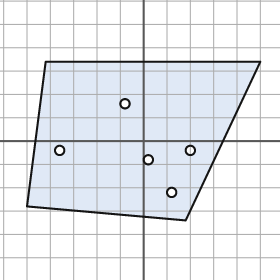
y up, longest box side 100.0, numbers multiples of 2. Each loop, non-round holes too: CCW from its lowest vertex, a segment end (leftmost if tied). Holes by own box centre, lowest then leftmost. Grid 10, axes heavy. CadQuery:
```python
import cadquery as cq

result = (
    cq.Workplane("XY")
    .moveTo(18.0, -34.0)
    .lineTo(50.0, 34.0)
    .lineTo(-42.0, 34.0)
    .lineTo(-50.0, -28.0)
    .close()
    .moveTo(12.0, -22.0)
    .circle(2.0)
    .moveTo(2.0, -8.0)
    .circle(2.0)
    .moveTo(-36.0, -4.0)
    .circle(2.0)
    .moveTo(20.0, -4.0)
    .circle(2.0)
    .moveTo(-8.0, 16.0)
    .circle(2.0)
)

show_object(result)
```